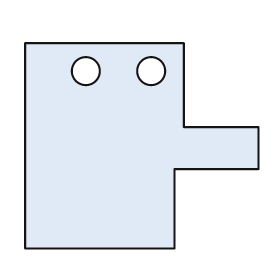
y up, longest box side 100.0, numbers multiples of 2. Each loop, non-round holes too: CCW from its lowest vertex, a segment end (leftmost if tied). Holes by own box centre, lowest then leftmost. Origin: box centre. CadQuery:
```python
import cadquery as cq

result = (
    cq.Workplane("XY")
    .moveTo(-50.0, -44.0)
    .lineTo(14.0, -44.0)
    .lineTo(14.0, -10.0)
    .lineTo(50.0, -10.0)
    .lineTo(50.0, 8.0)
    .lineTo(18.0, 8.0)
    .lineTo(18.0, 44.0)
    .lineTo(-50.0, 44.0)
    .close()
    .moveTo(-24.0, 32.0)
    .circle(6.0)
    .moveTo(4.0, 32.0)
    .circle(6.0)
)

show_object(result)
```